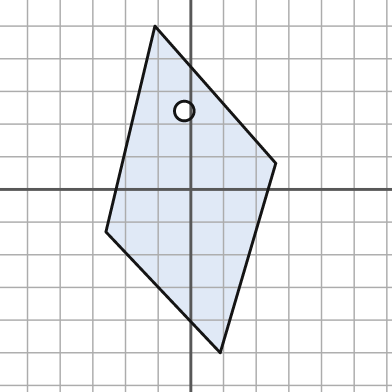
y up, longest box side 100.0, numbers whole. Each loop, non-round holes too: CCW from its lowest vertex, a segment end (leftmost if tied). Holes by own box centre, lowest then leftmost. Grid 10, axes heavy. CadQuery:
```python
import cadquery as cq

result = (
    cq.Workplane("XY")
    .moveTo(9.0, -50.0)
    .lineTo(26.0, 8.0)
    .lineTo(-11.0, 50.0)
    .lineTo(-26.0, -13.0)
    .close()
    .moveTo(-2.0, 24.0)
    .circle(3.0)
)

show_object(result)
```